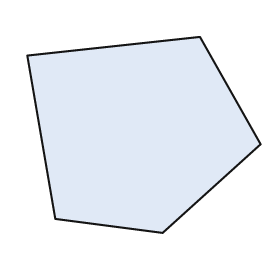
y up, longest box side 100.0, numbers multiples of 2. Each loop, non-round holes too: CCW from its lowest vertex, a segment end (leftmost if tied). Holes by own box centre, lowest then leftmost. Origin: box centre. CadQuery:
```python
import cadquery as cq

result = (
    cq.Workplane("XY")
    .moveTo(8.0, -42.0)
    .lineTo(50.0, -4.0)
    .lineTo(24.0, 42.0)
    .lineTo(-50.0, 34.0)
    .lineTo(-38.0, -36.0)
    .close()
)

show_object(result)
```